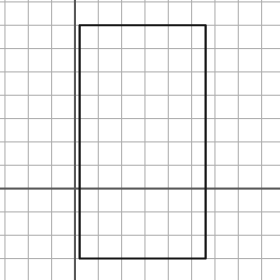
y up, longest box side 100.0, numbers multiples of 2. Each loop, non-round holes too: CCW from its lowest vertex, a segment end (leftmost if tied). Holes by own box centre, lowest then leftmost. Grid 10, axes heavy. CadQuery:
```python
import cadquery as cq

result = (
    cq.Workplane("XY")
    .moveTo(2.0, -30.0)
    .lineTo(56.0, -30.0)
    .lineTo(56.0, 70.0)
    .lineTo(2.0, 70.0)
    .close()
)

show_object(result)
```